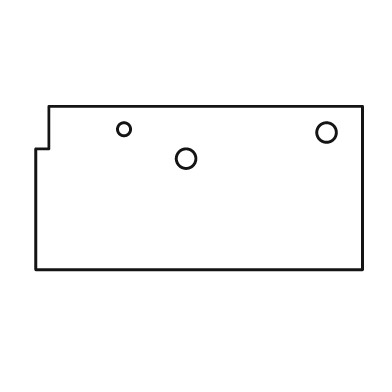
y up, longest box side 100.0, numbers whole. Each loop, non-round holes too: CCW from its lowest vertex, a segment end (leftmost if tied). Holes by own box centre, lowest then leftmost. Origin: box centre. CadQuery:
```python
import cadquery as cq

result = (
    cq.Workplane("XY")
    .moveTo(-50.0, -25.0)
    .lineTo(50.0, -25.0)
    .lineTo(50.0, 25.0)
    .lineTo(-46.0, 25.0)
    .lineTo(-46.0, 12.0)
    .lineTo(-50.0, 12.0)
    .close()
    .moveTo(-4.0, 9.0)
    .circle(3.0)
    .moveTo(39.0, 17.0)
    .circle(3.0)
    .moveTo(-23.0, 18.0)
    .circle(2.0)
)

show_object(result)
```